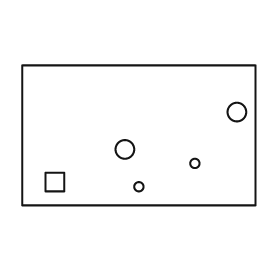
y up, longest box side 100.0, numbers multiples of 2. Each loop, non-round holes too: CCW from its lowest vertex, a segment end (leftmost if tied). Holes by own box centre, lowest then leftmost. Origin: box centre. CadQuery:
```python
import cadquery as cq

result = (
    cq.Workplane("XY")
    .moveTo(-50.0, -30.0)
    .lineTo(50.0, -30.0)
    .lineTo(50.0, 30.0)
    .lineTo(-50.0, 30.0)
    .close()
    .moveTo(0.0, -22.0)
    .circle(2.0)
    .moveTo(-40.0, -24.0)
    .lineTo(-32.0, -24.0)
    .lineTo(-32.0, -16.0)
    .lineTo(-40.0, -16.0)
    .close()
    .moveTo(24.0, -12.0)
    .circle(2.0)
    .moveTo(-6.0, -6.0)
    .circle(4.0)
    .moveTo(42.0, 10.0)
    .circle(4.0)
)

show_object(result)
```